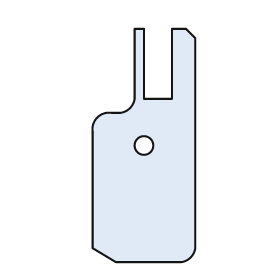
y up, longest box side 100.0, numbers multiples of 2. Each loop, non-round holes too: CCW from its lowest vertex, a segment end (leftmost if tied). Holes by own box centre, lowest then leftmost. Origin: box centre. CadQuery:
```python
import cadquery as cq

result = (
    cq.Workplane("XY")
    .moveTo(-12.0, -50.0)
    .lineTo(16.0, -50.0)
    .threePointArc((20.0, -48.0), (22.0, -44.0))
    .lineTo(22.0, 46.0)
    .lineTo(18.0, 50.0)
    .lineTo(12.0, 50.0)
    .lineTo(12.0, 20.0)
    .lineTo(0.0, 20.0)
    .lineTo(0.0, 50.0)
    .lineTo(-4.0, 50.0)
    .lineTo(-4.0, 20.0)
    .threePointArc((-6.0, 16.0), (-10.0, 14.0))
    .lineTo(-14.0, 14.0)
    .threePointArc((-20.0, 12.0), (-22.0, 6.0))
    .lineTo(-22.0, -44.0)
    .close()
    .moveTo(0.0, 0.0)
    .circle(4.0)
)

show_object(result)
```